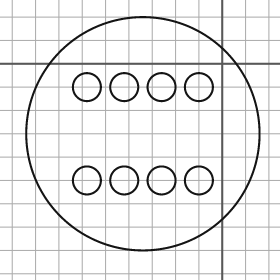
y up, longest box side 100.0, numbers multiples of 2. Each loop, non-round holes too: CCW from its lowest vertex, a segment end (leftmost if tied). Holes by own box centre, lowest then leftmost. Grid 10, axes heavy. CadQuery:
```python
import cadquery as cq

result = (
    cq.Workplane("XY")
    .moveTo(-34.0, -30.0)
    .circle(50.0)
    .moveTo(-58.0, -50.0)
    .circle(6.0)
    .moveTo(-42.0, -50.0)
    .circle(6.0)
    .moveTo(-26.0, -50.0)
    .circle(6.0)
    .moveTo(-10.0, -50.0)
    .circle(6.0)
    .moveTo(-58.0, -10.0)
    .circle(6.0)
    .moveTo(-42.0, -10.0)
    .circle(6.0)
    .moveTo(-26.0, -10.0)
    .circle(6.0)
    .moveTo(-10.0, -10.0)
    .circle(6.0)
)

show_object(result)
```